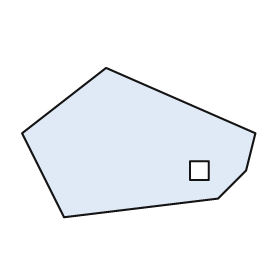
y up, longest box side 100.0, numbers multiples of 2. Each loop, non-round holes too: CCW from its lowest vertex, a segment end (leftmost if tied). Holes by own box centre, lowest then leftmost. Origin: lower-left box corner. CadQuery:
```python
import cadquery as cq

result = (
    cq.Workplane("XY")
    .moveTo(18.0, 0.0)
    .lineTo(84.0, 8.0)
    .lineTo(96.0, 20.0)
    .lineTo(100.0, 36.0)
    .lineTo(36.0, 64.0)
    .lineTo(0.0, 36.0)
    .close()
    .moveTo(72.0, 16.0)
    .lineTo(80.0, 16.0)
    .lineTo(80.0, 24.0)
    .lineTo(72.0, 24.0)
    .close()
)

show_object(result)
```